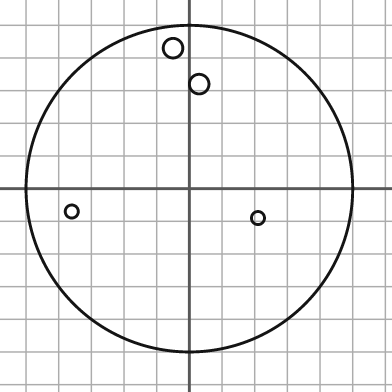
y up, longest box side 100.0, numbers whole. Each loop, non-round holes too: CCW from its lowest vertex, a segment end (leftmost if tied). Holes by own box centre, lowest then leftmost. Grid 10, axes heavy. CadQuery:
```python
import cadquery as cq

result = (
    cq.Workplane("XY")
    .moveTo(0.0, 0.0)
    .circle(50.0)
    .moveTo(21.0, -9.0)
    .circle(2.0)
    .moveTo(-36.0, -7.0)
    .circle(2.0)
    .moveTo(3.0, 32.0)
    .circle(3.0)
    .moveTo(-5.0, 43.0)
    .circle(3.0)
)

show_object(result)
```